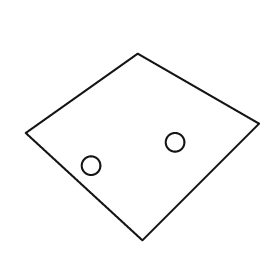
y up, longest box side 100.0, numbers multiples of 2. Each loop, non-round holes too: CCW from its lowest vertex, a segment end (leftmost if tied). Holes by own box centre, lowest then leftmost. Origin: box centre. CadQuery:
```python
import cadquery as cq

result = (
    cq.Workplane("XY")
    .moveTo(0.0, -40.0)
    .lineTo(50.0, 10.0)
    .lineTo(-2.0, 40.0)
    .lineTo(-50.0, 6.0)
    .close()
    .moveTo(-22.0, -8.0)
    .circle(4.0)
    .moveTo(14.0, 2.0)
    .circle(4.0)
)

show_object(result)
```